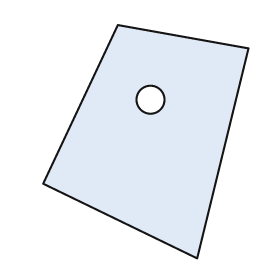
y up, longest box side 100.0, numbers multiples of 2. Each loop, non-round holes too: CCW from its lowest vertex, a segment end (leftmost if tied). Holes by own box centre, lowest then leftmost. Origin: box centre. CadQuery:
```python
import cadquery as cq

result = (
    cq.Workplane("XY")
    .moveTo(22.0, -50.0)
    .lineTo(44.0, 40.0)
    .lineTo(-12.0, 50.0)
    .lineTo(-44.0, -18.0)
    .close()
    .moveTo(2.0, 18.0)
    .circle(6.0)
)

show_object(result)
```